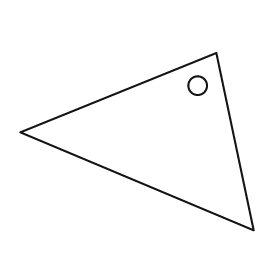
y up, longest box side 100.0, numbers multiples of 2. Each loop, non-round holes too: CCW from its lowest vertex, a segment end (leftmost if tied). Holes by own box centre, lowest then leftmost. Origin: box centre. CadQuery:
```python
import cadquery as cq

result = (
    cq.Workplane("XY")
    .moveTo(50.0, -38.0)
    .lineTo(34.0, 38.0)
    .lineTo(-50.0, 4.0)
    .close()
    .moveTo(26.0, 24.0)
    .circle(4.0)
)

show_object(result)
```